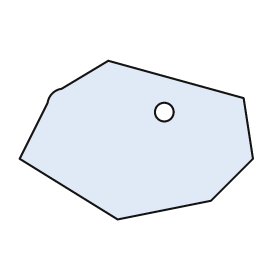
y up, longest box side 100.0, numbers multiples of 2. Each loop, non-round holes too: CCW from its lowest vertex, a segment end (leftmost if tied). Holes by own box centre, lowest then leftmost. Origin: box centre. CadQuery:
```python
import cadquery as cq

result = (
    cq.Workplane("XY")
    .moveTo(-8.0, -34.0)
    .lineTo(32.0, -26.0)
    .lineTo(50.0, -8.0)
    .lineTo(46.0, 18.0)
    .lineTo(-12.0, 34.0)
    .lineTo(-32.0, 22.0)
    .threePointArc((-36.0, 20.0), (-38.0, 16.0))
    .lineTo(-50.0, -8.0)
    .close()
    .moveTo(12.0, 12.0)
    .circle(4.0)
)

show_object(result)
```